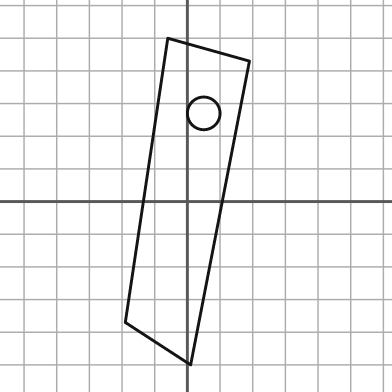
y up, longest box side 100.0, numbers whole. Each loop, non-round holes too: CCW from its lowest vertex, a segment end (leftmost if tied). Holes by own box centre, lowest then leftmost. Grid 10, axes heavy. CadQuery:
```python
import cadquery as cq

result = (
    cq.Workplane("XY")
    .moveTo(1.0, -50.0)
    .lineTo(19.0, 43.0)
    .lineTo(-6.0, 50.0)
    .lineTo(-19.0, -37.0)
    .close()
    .moveTo(5.0, 27.0)
    .circle(5.0)
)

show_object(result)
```